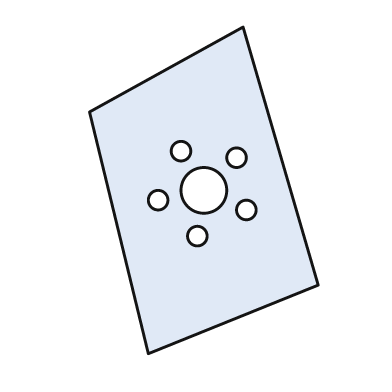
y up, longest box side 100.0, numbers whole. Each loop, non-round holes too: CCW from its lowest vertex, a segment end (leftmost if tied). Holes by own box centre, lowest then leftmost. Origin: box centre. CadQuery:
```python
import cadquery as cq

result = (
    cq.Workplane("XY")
    .moveTo(-17.0, -50.0)
    .lineTo(35.0, -29.0)
    .lineTo(12.0, 50.0)
    .lineTo(-35.0, 24.0)
    .close()
    .moveTo(-2.0, -14.0)
    .circle(3.0)
    .moveTo(13.0, -6.0)
    .circle(3.0)
    .moveTo(-14.0, -3.0)
    .circle(3.0)
    .moveTo(0.0, 0.0)
    .circle(7.0)
    .moveTo(10.0, 10.0)
    .circle(3.0)
    .moveTo(-7.0, 12.0)
    .circle(3.0)
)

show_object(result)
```